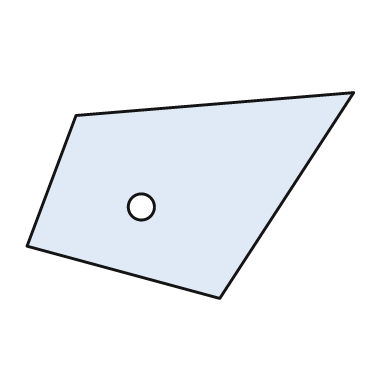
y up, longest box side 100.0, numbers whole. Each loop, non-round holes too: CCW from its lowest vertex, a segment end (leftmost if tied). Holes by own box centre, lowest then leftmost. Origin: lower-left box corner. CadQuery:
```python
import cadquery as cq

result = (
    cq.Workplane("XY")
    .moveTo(59.0, 0.0)
    .lineTo(100.0, 63.0)
    .lineTo(15.0, 56.0)
    .lineTo(0.0, 16.0)
    .close()
    .moveTo(35.0, 28.0)
    .circle(4.0)
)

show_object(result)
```